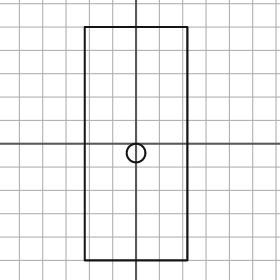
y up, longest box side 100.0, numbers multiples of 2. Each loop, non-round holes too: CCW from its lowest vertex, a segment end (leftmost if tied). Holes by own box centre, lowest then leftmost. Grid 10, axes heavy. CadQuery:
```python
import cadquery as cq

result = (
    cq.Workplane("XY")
    .moveTo(-22.0, -50.0)
    .lineTo(22.0, -50.0)
    .lineTo(22.0, 50.0)
    .lineTo(-22.0, 50.0)
    .close()
    .moveTo(0.0, -4.0)
    .circle(4.0)
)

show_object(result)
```